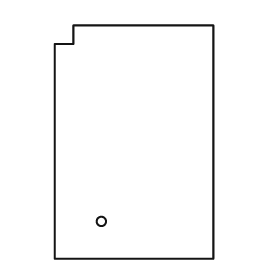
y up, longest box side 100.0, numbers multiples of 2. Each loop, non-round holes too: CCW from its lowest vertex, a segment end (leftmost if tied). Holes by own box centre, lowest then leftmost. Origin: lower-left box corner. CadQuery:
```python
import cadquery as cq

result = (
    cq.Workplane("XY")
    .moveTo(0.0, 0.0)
    .lineTo(68.0, 0.0)
    .lineTo(68.0, 100.0)
    .lineTo(8.0, 100.0)
    .lineTo(8.0, 92.0)
    .lineTo(0.0, 92.0)
    .close()
    .moveTo(20.0, 16.0)
    .circle(2.0)
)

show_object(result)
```